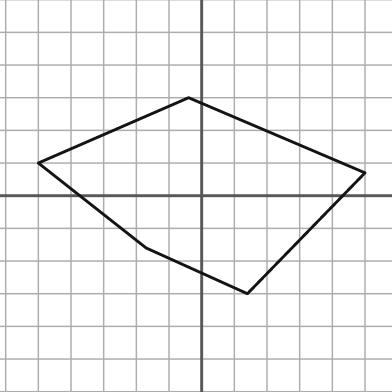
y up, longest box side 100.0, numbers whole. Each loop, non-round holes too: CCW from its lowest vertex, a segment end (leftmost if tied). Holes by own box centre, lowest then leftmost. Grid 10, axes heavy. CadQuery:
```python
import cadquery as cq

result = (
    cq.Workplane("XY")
    .moveTo(14.0, -30.0)
    .lineTo(50.0, 7.0)
    .lineTo(-4.0, 30.0)
    .lineTo(-50.0, 10.0)
    .lineTo(-17.0, -16.0)
    .close()
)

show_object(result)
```